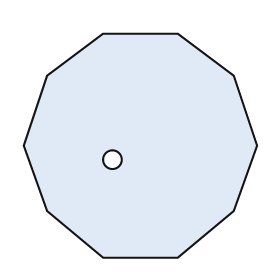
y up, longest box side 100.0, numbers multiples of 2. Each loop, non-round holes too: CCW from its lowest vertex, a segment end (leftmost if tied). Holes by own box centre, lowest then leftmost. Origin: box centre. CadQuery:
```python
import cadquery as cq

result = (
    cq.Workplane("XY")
    .moveTo(-16.0, -48.0)
    .lineTo(16.0, -48.0)
    .lineTo(40.0, -28.0)
    .lineTo(50.0, 0.0)
    .lineTo(40.0, 30.0)
    .lineTo(16.0, 48.0)
    .lineTo(-16.0, 48.0)
    .lineTo(-40.0, 30.0)
    .lineTo(-50.0, 0.0)
    .lineTo(-40.0, -28.0)
    .close()
    .moveTo(-12.0, -6.0)
    .circle(4.0)
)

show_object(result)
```